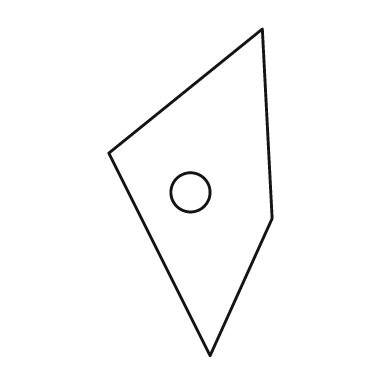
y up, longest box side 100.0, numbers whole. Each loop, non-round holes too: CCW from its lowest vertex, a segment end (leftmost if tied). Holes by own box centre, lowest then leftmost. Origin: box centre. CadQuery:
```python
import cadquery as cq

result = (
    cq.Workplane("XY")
    .moveTo(6.0, -50.0)
    .lineTo(25.0, -8.0)
    .lineTo(22.0, 50.0)
    .lineTo(-25.0, 12.0)
    .close()
    .moveTo(0.0, 0.0)
    .circle(6.0)
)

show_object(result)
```